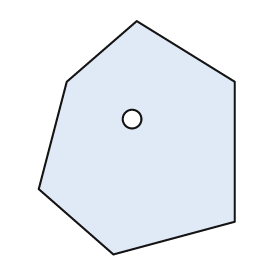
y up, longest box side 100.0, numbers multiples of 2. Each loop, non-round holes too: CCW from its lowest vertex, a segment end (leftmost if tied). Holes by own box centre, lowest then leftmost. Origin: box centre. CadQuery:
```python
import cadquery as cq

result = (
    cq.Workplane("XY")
    .moveTo(-10.0, -50.0)
    .lineTo(42.0, -36.0)
    .lineTo(42.0, 24.0)
    .lineTo(0.0, 50.0)
    .lineTo(-30.0, 24.0)
    .lineTo(-42.0, -22.0)
    .close()
    .moveTo(-2.0, 8.0)
    .circle(4.0)
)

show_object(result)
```